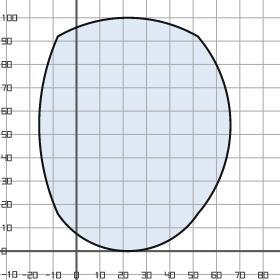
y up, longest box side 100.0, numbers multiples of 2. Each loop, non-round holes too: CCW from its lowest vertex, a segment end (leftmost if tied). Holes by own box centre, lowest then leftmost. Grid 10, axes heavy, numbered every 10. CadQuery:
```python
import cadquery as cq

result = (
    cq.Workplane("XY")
    .moveTo(-8.0, 16.0)
    .threePointArc((22.0, 0.0), (52.0, 16.0))
    .threePointArc((66.0, 54.0), (52.0, 92.0))
    .threePointArc((22.0, 100.0), (-8.0, 92.0))
    .threePointArc((-16.0, 54.0), (-8.0, 16.0))
    .close()
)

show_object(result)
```